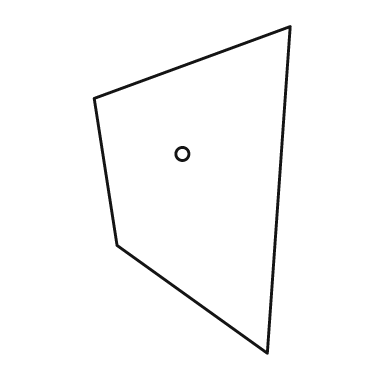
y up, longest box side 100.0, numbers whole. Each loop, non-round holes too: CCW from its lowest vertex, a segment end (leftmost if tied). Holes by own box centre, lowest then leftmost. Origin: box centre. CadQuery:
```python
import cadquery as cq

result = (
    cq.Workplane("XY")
    .moveTo(23.0, -50.0)
    .lineTo(30.0, 50.0)
    .lineTo(-30.0, 28.0)
    .lineTo(-23.0, -17.0)
    .close()
    .moveTo(-3.0, 11.0)
    .circle(2.0)
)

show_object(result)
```